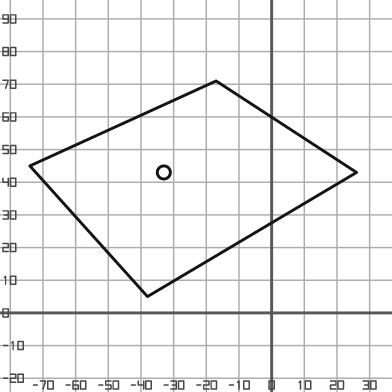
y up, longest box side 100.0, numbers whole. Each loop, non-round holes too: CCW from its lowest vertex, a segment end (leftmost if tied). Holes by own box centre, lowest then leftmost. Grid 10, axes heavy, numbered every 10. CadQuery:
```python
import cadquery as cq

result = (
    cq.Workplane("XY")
    .moveTo(-38.0, 5.0)
    .lineTo(26.0, 43.0)
    .lineTo(-17.0, 71.0)
    .lineTo(-74.0, 45.0)
    .close()
    .moveTo(-33.0, 43.0)
    .circle(2.0)
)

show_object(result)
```